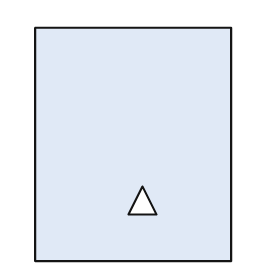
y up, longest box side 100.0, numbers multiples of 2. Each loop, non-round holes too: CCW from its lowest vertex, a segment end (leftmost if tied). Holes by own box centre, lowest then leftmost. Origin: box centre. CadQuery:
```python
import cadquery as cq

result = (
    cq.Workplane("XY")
    .moveTo(-42.0, -50.0)
    .lineTo(42.0, -50.0)
    .lineTo(42.0, 50.0)
    .lineTo(-42.0, 50.0)
    .close()
    .moveTo(-2.0, -30.0)
    .lineTo(10.0, -30.0)
    .lineTo(4.0, -18.0)
    .close()
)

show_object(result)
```